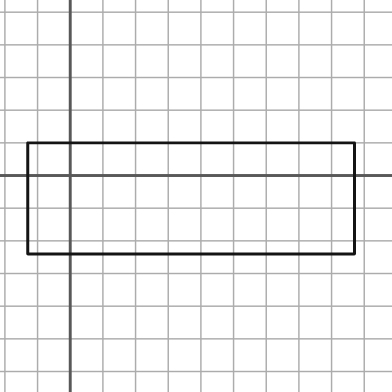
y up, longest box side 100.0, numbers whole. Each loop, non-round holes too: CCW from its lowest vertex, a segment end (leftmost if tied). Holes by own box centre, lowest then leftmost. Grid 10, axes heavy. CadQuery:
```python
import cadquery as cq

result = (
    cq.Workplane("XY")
    .moveTo(-13.0, -24.0)
    .lineTo(87.0, -24.0)
    .lineTo(87.0, 10.0)
    .lineTo(-13.0, 10.0)
    .close()
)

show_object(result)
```